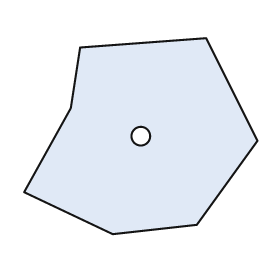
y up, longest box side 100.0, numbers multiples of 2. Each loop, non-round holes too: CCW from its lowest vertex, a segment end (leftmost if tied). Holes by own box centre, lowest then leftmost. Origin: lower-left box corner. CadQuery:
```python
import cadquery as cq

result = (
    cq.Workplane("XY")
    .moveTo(38.0, 0.0)
    .lineTo(74.0, 4.0)
    .lineTo(100.0, 40.0)
    .lineTo(78.0, 84.0)
    .lineTo(24.0, 80.0)
    .lineTo(20.0, 54.0)
    .lineTo(0.0, 18.0)
    .close()
    .moveTo(50.0, 42.0)
    .circle(4.0)
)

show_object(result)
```